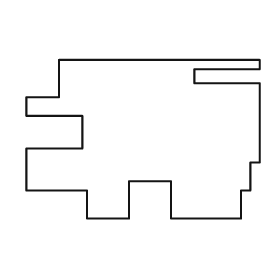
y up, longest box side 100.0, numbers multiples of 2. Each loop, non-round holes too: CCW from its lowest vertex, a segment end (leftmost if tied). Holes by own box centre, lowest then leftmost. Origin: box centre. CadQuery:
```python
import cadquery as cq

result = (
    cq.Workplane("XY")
    .moveTo(-24.0, -34.0)
    .lineTo(-6.0, -34.0)
    .lineTo(-6.0, -18.0)
    .lineTo(12.0, -18.0)
    .lineTo(12.0, -34.0)
    .lineTo(42.0, -34.0)
    .lineTo(42.0, -22.0)
    .lineTo(46.0, -22.0)
    .lineTo(46.0, -10.0)
    .lineTo(50.0, -10.0)
    .lineTo(50.0, 24.0)
    .lineTo(22.0, 24.0)
    .lineTo(22.0, 30.0)
    .lineTo(50.0, 30.0)
    .lineTo(50.0, 34.0)
    .lineTo(-36.0, 34.0)
    .lineTo(-36.0, 18.0)
    .lineTo(-50.0, 18.0)
    .lineTo(-50.0, 10.0)
    .lineTo(-26.0, 10.0)
    .lineTo(-26.0, -4.0)
    .lineTo(-50.0, -4.0)
    .lineTo(-50.0, -22.0)
    .lineTo(-24.0, -22.0)
    .close()
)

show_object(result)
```